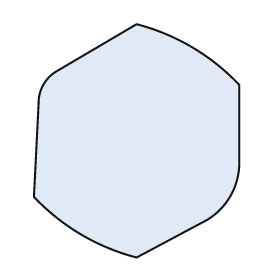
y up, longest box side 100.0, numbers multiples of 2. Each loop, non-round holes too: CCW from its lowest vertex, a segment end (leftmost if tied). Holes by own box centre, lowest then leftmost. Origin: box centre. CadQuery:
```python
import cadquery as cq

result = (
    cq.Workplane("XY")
    .moveTo(0.0, -50.0)
    .lineTo(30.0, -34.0)
    .threePointArc((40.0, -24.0), (44.0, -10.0))
    .lineTo(44.0, 24.0)
    .threePointArc((24.0, 40.0), (0.0, 50.0))
    .lineTo(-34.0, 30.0)
    .threePointArc((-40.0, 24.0), (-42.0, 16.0))
    .lineTo(-44.0, -24.0)
    .threePointArc((-24.0, -40.0), (0.0, -50.0))
    .close()
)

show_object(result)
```